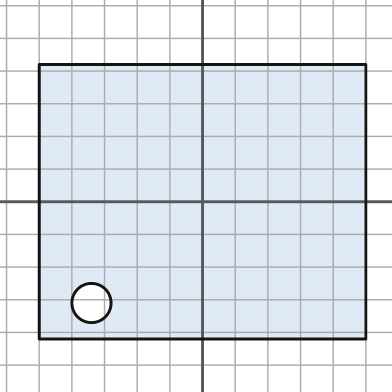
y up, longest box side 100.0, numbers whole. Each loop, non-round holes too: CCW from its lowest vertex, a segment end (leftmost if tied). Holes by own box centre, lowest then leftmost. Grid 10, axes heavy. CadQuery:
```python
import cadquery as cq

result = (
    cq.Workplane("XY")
    .moveTo(-50.0, -42.0)
    .lineTo(50.0, -42.0)
    .lineTo(50.0, 42.0)
    .lineTo(-50.0, 42.0)
    .close()
    .moveTo(-34.0, -31.0)
    .circle(6.0)
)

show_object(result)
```